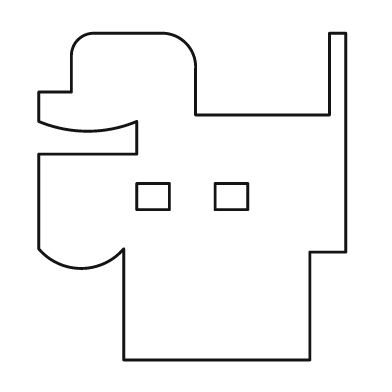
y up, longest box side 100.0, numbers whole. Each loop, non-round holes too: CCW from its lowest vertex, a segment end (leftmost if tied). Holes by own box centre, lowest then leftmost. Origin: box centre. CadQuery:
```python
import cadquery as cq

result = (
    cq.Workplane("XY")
    .moveTo(-21.0, -50.0)
    .lineTo(36.0, -50.0)
    .lineTo(36.0, -17.0)
    .lineTo(47.0, -17.0)
    .lineTo(47.0, 50.0)
    .lineTo(42.0, 50.0)
    .lineTo(42.0, 25.0)
    .lineTo(1.0, 25.0)
    .lineTo(1.0, 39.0)
    .threePointArc((-2.0, 47.0), (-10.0, 50.0))
    .lineTo(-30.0, 50.0)
    .threePointArc((-35.0, 48.0), (-37.0, 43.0))
    .lineTo(-37.0, 32.0)
    .lineTo(-47.0, 32.0)
    .lineTo(-47.0, 23.0)
    .threePointArc((-32.0, 20.0), (-17.0, 23.0))
    .lineTo(-17.0, 13.0)
    .lineTo(-47.0, 13.0)
    .lineTo(-47.0, -16.0)
    .threePointArc((-34.0, -22.0), (-21.0, -16.0))
    .close()
    .moveTo(-17.0, -4.0)
    .lineTo(-7.0, -4.0)
    .lineTo(-7.0, 4.0)
    .lineTo(-17.0, 4.0)
    .close()
    .moveTo(7.0, -4.0)
    .lineTo(17.0, -4.0)
    .lineTo(17.0, 4.0)
    .lineTo(7.0, 4.0)
    .close()
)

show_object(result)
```